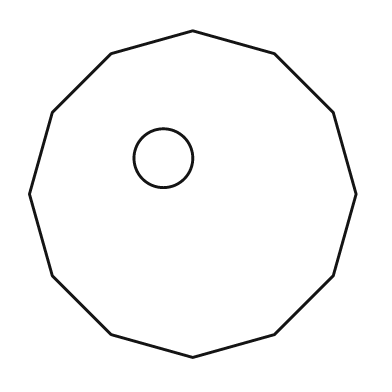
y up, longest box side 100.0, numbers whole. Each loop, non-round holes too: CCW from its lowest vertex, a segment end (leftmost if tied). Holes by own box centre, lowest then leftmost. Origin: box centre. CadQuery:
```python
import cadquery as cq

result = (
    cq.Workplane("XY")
    .moveTo(0.0, -50.0)
    .lineTo(25.0, -43.0)
    .lineTo(43.0, -25.0)
    .lineTo(50.0, 0.0)
    .lineTo(43.0, 25.0)
    .lineTo(25.0, 43.0)
    .lineTo(0.0, 50.0)
    .lineTo(-25.0, 43.0)
    .lineTo(-43.0, 25.0)
    .lineTo(-50.0, 0.0)
    .lineTo(-43.0, -25.0)
    .lineTo(-25.0, -43.0)
    .close()
    .moveTo(-9.0, 11.0)
    .circle(9.0)
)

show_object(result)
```